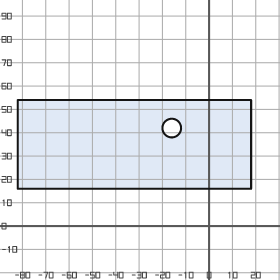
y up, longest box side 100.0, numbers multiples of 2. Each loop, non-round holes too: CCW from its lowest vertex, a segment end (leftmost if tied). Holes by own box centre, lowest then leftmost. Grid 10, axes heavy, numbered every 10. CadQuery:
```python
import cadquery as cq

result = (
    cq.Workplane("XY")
    .moveTo(-82.0, 16.0)
    .lineTo(18.0, 16.0)
    .lineTo(18.0, 54.0)
    .lineTo(-82.0, 54.0)
    .close()
    .moveTo(-16.0, 42.0)
    .circle(4.0)
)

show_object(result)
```